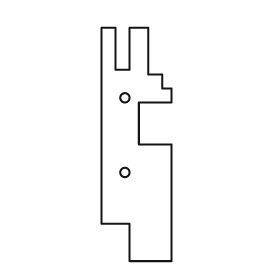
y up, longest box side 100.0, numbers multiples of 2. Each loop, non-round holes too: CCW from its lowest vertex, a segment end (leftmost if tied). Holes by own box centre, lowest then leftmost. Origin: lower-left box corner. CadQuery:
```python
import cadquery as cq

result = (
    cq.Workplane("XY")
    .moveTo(12.0, 0.0)
    .lineTo(30.0, 0.0)
    .lineTo(30.0, 50.0)
    .lineTo(16.0, 50.0)
    .lineTo(16.0, 68.0)
    .lineTo(30.0, 68.0)
    .lineTo(30.0, 74.0)
    .lineTo(26.0, 74.0)
    .lineTo(26.0, 80.0)
    .lineTo(20.0, 80.0)
    .lineTo(20.0, 100.0)
    .lineTo(12.0, 100.0)
    .lineTo(12.0, 82.0)
    .lineTo(6.0, 82.0)
    .lineTo(6.0, 100.0)
    .lineTo(0.0, 100.0)
    .lineTo(0.0, 16.0)
    .lineTo(12.0, 16.0)
    .close()
    .moveTo(10.0, 38.0)
    .circle(2.0)
    .moveTo(10.0, 70.0)
    .circle(2.0)
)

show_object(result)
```